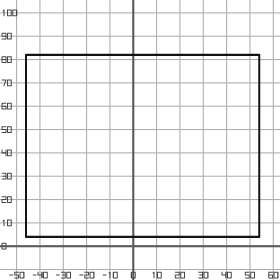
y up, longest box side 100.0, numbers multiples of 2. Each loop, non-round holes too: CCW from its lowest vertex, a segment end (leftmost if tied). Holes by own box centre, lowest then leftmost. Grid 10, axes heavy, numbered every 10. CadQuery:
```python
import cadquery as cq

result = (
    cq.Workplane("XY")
    .moveTo(-46.0, 4.0)
    .lineTo(54.0, 4.0)
    .lineTo(54.0, 82.0)
    .lineTo(-46.0, 82.0)
    .close()
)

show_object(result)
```